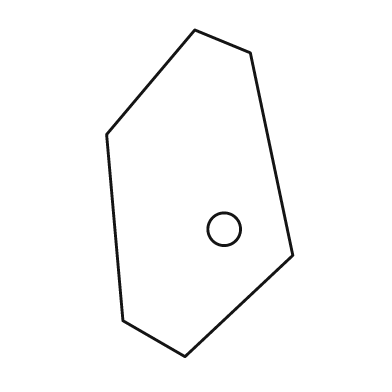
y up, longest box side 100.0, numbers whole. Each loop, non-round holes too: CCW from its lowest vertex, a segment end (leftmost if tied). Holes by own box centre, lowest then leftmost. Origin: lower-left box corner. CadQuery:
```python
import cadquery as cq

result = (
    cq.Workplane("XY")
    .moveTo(24.0, 0.0)
    .lineTo(57.0, 31.0)
    .lineTo(44.0, 93.0)
    .lineTo(27.0, 100.0)
    .lineTo(0.0, 68.0)
    .lineTo(5.0, 11.0)
    .close()
    .moveTo(36.0, 39.0)
    .circle(5.0)
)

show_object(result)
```